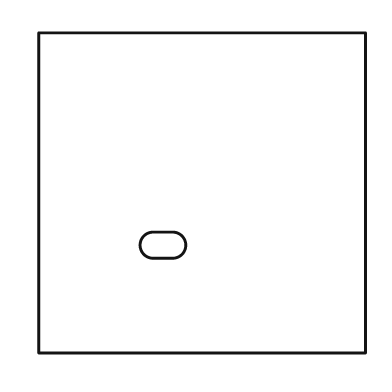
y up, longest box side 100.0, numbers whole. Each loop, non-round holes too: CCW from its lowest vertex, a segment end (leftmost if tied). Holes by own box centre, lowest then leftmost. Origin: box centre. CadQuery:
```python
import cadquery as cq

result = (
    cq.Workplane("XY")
    .moveTo(-50.0, -49.0)
    .lineTo(50.0, -49.0)
    .lineTo(50.0, 49.0)
    .lineTo(-50.0, 49.0)
    .close()
    .moveTo(-15.0, -20.0)
    .lineTo(-9.0, -20.0)
    .threePointArc((-5.0, -16.0), (-9.0, -12.0))
    .lineTo(-15.0, -12.0)
    .threePointArc((-19.0, -16.0), (-15.0, -20.0))
    .close()
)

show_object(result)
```